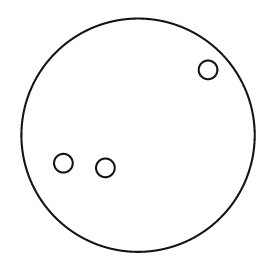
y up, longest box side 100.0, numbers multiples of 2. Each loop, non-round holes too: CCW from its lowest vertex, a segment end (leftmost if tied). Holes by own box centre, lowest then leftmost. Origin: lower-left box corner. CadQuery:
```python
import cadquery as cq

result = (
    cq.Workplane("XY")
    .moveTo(50.0, 50.0)
    .circle(50.0)
    .moveTo(36.0, 36.0)
    .circle(4.0)
    .moveTo(18.0, 38.0)
    .circle(4.0)
    .moveTo(80.0, 78.0)
    .circle(4.0)
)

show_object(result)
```